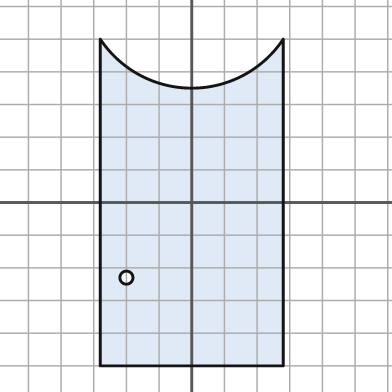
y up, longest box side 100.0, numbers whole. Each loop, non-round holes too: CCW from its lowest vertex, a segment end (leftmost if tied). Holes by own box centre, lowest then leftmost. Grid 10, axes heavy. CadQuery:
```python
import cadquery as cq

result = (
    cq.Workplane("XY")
    .moveTo(-28.0, -50.0)
    .lineTo(28.0, -50.0)
    .lineTo(28.0, 50.0)
    .threePointArc((0.0, 35.0), (-28.0, 50.0))
    .close()
    .moveTo(-20.0, -23.0)
    .circle(2.0)
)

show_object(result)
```